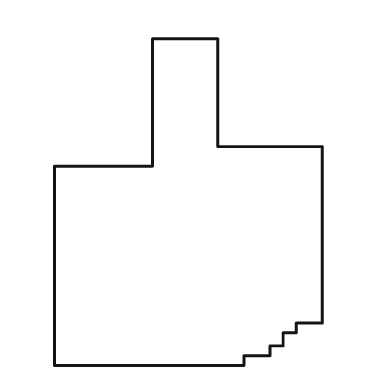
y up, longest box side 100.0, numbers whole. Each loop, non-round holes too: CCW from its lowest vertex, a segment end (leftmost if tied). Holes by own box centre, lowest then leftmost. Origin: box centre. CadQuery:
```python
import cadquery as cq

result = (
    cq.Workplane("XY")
    .moveTo(-41.0, -50.0)
    .lineTo(17.0, -50.0)
    .lineTo(17.0, -47.0)
    .lineTo(25.0, -47.0)
    .lineTo(25.0, -44.0)
    .lineTo(29.0, -44.0)
    .lineTo(29.0, -40.0)
    .lineTo(33.0, -40.0)
    .lineTo(33.0, -37.0)
    .lineTo(41.0, -37.0)
    .lineTo(41.0, 17.0)
    .lineTo(9.0, 17.0)
    .lineTo(9.0, 50.0)
    .lineTo(-11.0, 50.0)
    .lineTo(-11.0, 11.0)
    .lineTo(-41.0, 11.0)
    .close()
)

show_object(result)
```